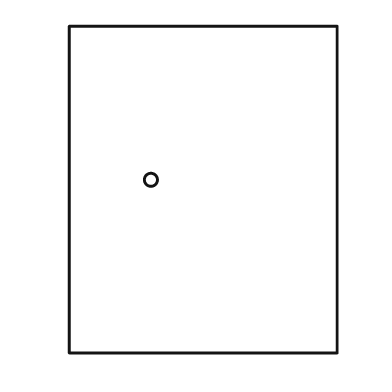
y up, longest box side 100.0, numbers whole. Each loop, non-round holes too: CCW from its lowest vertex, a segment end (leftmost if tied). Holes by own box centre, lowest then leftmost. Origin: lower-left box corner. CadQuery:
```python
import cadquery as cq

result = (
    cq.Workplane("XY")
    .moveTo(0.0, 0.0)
    .lineTo(82.0, 0.0)
    .lineTo(82.0, 100.0)
    .lineTo(0.0, 100.0)
    .close()
    .moveTo(25.0, 53.0)
    .circle(2.0)
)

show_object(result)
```